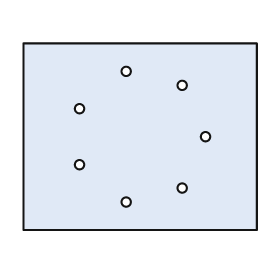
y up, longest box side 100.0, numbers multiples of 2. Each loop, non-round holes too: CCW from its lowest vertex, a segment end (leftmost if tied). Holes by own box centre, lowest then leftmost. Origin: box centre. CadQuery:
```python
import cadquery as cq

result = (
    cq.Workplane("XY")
    .moveTo(-50.0, -40.0)
    .lineTo(50.0, -40.0)
    .lineTo(50.0, 40.0)
    .lineTo(-50.0, 40.0)
    .close()
    .moveTo(-6.0, -28.0)
    .circle(2.0)
    .moveTo(18.0, -22.0)
    .circle(2.0)
    .moveTo(-26.0, -12.0)
    .circle(2.0)
    .moveTo(28.0, 0.0)
    .circle(2.0)
    .moveTo(-26.0, 12.0)
    .circle(2.0)
    .moveTo(18.0, 22.0)
    .circle(2.0)
    .moveTo(-6.0, 28.0)
    .circle(2.0)
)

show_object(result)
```